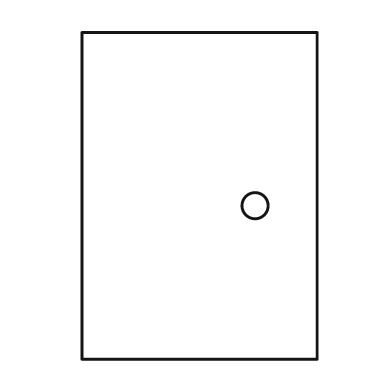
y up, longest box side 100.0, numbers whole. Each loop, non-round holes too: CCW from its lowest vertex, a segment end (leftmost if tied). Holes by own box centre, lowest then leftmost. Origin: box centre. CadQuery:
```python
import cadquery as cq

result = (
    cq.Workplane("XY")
    .moveTo(-36.0, -50.0)
    .lineTo(36.0, -50.0)
    .lineTo(36.0, 50.0)
    .lineTo(-36.0, 50.0)
    .close()
    .moveTo(17.0, -3.0)
    .circle(4.0)
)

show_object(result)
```